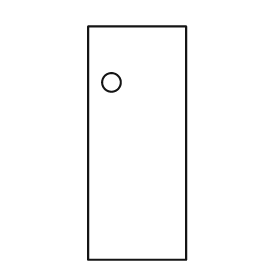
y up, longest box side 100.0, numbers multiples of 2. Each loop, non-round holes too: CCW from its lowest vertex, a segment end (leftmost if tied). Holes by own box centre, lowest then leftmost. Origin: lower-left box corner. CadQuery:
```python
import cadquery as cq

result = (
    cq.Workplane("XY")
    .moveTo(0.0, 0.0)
    .lineTo(42.0, 0.0)
    .lineTo(42.0, 100.0)
    .lineTo(0.0, 100.0)
    .close()
    .moveTo(10.0, 76.0)
    .circle(4.0)
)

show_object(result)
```